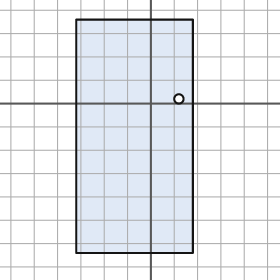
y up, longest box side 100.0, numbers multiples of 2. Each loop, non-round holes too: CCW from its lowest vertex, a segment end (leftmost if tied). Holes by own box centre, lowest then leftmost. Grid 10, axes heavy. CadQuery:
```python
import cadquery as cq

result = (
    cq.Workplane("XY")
    .moveTo(-32.0, -64.0)
    .lineTo(18.0, -64.0)
    .lineTo(18.0, 36.0)
    .lineTo(-32.0, 36.0)
    .close()
    .moveTo(12.0, 2.0)
    .circle(2.0)
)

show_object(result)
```